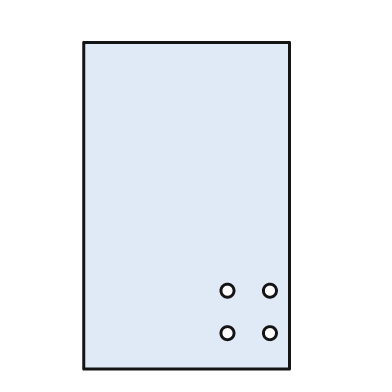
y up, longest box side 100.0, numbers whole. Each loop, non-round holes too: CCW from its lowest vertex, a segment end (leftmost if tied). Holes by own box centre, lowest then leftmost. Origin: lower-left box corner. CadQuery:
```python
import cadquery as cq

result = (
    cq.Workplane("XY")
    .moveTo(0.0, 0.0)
    .lineTo(63.0, 0.0)
    .lineTo(63.0, 100.0)
    .lineTo(0.0, 100.0)
    .close()
    .moveTo(44.0, 11.0)
    .circle(2.0)
    .moveTo(57.0, 11.0)
    .circle(2.0)
    .moveTo(44.0, 24.0)
    .circle(2.0)
    .moveTo(57.0, 24.0)
    .circle(2.0)
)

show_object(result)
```